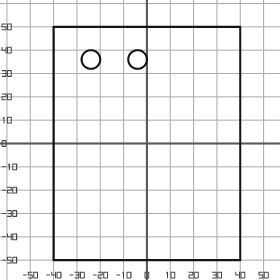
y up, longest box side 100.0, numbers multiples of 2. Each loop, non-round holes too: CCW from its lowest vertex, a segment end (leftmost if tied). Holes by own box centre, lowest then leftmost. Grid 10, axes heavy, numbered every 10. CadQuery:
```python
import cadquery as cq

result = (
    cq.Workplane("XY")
    .moveTo(-40.0, -50.0)
    .lineTo(40.0, -50.0)
    .lineTo(40.0, 50.0)
    .lineTo(-40.0, 50.0)
    .close()
    .moveTo(-24.0, 36.0)
    .circle(4.0)
    .moveTo(-4.0, 36.0)
    .circle(4.0)
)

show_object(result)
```